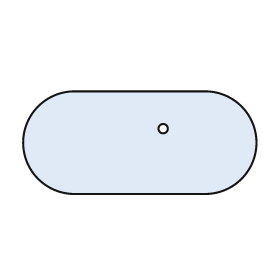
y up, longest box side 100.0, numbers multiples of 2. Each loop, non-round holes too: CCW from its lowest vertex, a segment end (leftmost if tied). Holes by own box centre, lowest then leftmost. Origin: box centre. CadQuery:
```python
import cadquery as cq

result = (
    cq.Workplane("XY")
    .moveTo(-28.0, -22.0)
    .lineTo(28.0, -22.0)
    .threePointArc((50.0, 0.0), (28.0, 22.0))
    .lineTo(-28.0, 22.0)
    .threePointArc((-50.0, 0.0), (-28.0, -22.0))
    .close()
    .moveTo(10.0, 6.0)
    .circle(2.0)
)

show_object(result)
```